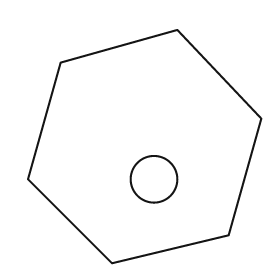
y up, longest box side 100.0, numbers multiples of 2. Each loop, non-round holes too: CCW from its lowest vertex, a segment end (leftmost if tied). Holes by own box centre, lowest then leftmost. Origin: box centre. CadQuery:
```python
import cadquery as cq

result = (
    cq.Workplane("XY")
    .moveTo(-14.0, -50.0)
    .lineTo(36.0, -38.0)
    .lineTo(50.0, 12.0)
    .lineTo(14.0, 50.0)
    .lineTo(-36.0, 36.0)
    .lineTo(-50.0, -14.0)
    .close()
    .moveTo(4.0, -14.0)
    .circle(10.0)
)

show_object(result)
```